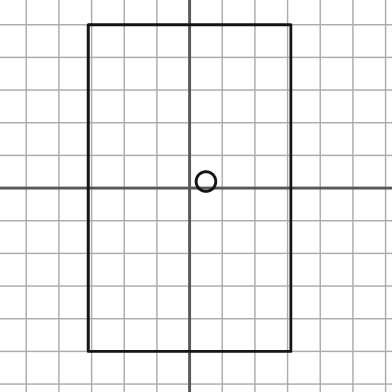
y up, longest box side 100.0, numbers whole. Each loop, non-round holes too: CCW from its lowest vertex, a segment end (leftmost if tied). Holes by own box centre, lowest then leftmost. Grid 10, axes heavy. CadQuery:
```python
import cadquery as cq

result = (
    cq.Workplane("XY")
    .moveTo(-31.0, -50.0)
    .lineTo(31.0, -50.0)
    .lineTo(31.0, 50.0)
    .lineTo(-31.0, 50.0)
    .close()
    .moveTo(5.0, 2.0)
    .circle(3.0)
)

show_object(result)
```